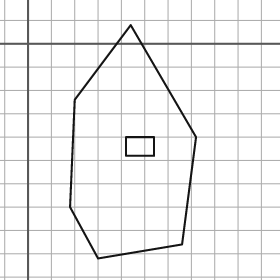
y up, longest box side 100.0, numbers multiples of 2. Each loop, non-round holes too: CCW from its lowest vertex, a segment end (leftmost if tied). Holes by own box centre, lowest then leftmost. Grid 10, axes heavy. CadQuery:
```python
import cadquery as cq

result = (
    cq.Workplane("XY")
    .moveTo(30.0, -92.0)
    .lineTo(66.0, -86.0)
    .lineTo(72.0, -40.0)
    .lineTo(44.0, 8.0)
    .lineTo(20.0, -24.0)
    .lineTo(18.0, -70.0)
    .close()
    .moveTo(42.0, -48.0)
    .lineTo(54.0, -48.0)
    .lineTo(54.0, -40.0)
    .lineTo(42.0, -40.0)
    .close()
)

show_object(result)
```